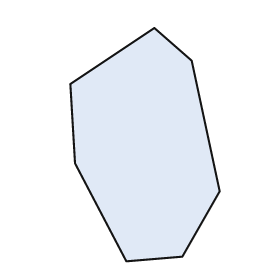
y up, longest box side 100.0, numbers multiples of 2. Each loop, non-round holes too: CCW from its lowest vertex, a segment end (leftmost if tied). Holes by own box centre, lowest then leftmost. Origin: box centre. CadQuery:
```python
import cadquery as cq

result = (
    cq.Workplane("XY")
    .moveTo(-8.0, -50.0)
    .lineTo(16.0, -48.0)
    .lineTo(32.0, -20.0)
    .lineTo(20.0, 36.0)
    .lineTo(4.0, 50.0)
    .lineTo(-32.0, 26.0)
    .lineTo(-30.0, -8.0)
    .close()
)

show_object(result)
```